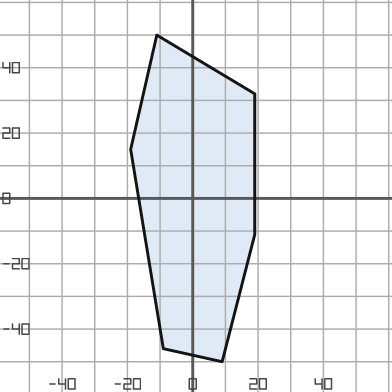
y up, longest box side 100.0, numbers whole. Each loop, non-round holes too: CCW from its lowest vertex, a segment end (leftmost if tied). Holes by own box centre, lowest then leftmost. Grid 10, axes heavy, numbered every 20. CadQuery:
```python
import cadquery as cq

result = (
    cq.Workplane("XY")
    .moveTo(9.0, -50.0)
    .lineTo(19.0, -11.0)
    .lineTo(19.0, 32.0)
    .lineTo(-11.0, 50.0)
    .lineTo(-19.0, 15.0)
    .lineTo(-9.0, -46.0)
    .close()
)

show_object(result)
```